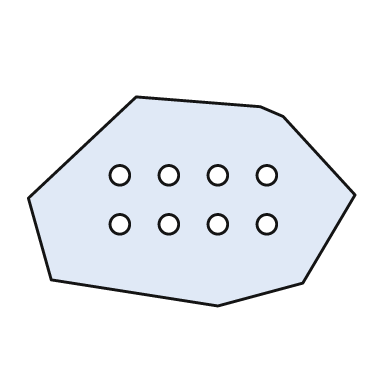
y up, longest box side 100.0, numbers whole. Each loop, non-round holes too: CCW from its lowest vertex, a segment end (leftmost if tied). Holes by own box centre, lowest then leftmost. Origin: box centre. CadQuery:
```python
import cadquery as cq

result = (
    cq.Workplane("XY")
    .moveTo(8.0, -32.0)
    .lineTo(34.0, -25.0)
    .lineTo(50.0, 2.0)
    .lineTo(28.0, 26.0)
    .lineTo(21.0, 29.0)
    .lineTo(-17.0, 32.0)
    .lineTo(-50.0, 1.0)
    .lineTo(-43.0, -24.0)
    .close()
    .moveTo(-22.0, -7.0)
    .circle(3.0)
    .moveTo(-7.0, -7.0)
    .circle(3.0)
    .moveTo(8.0, -7.0)
    .circle(3.0)
    .moveTo(23.0, -7.0)
    .circle(3.0)
    .moveTo(-22.0, 8.0)
    .circle(3.0)
    .moveTo(-7.0, 8.0)
    .circle(3.0)
    .moveTo(8.0, 8.0)
    .circle(3.0)
    .moveTo(23.0, 8.0)
    .circle(3.0)
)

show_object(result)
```